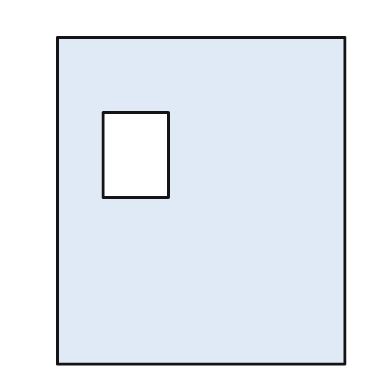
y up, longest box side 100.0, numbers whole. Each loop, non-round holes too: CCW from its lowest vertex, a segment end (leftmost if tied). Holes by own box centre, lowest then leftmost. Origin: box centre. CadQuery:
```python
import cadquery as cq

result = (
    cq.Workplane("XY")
    .moveTo(-44.0, -50.0)
    .lineTo(44.0, -50.0)
    .lineTo(44.0, 50.0)
    .lineTo(-44.0, 50.0)
    .close()
    .moveTo(-30.0, 1.0)
    .lineTo(-10.0, 1.0)
    .lineTo(-10.0, 27.0)
    .lineTo(-30.0, 27.0)
    .close()
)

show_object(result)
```